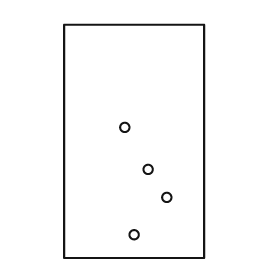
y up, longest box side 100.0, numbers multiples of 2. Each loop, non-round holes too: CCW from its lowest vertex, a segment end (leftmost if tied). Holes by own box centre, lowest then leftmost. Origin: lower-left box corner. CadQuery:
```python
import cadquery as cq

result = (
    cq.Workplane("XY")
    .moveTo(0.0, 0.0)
    .lineTo(60.0, 0.0)
    .lineTo(60.0, 100.0)
    .lineTo(0.0, 100.0)
    .close()
    .moveTo(30.0, 10.0)
    .circle(2.0)
    .moveTo(44.0, 26.0)
    .circle(2.0)
    .moveTo(36.0, 38.0)
    .circle(2.0)
    .moveTo(26.0, 56.0)
    .circle(2.0)
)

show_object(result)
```